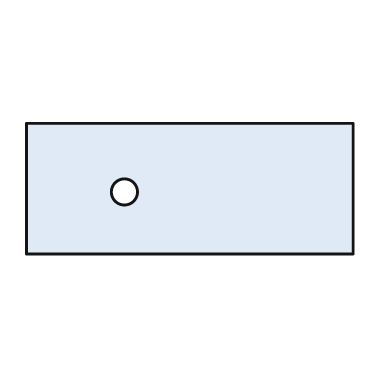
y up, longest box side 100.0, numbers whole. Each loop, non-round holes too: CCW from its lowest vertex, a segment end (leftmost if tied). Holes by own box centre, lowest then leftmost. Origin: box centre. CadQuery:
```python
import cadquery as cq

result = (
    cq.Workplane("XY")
    .moveTo(-50.0, -20.0)
    .lineTo(50.0, -20.0)
    .lineTo(50.0, 20.0)
    .lineTo(-50.0, 20.0)
    .close()
    .moveTo(-20.0, -1.0)
    .circle(4.0)
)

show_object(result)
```